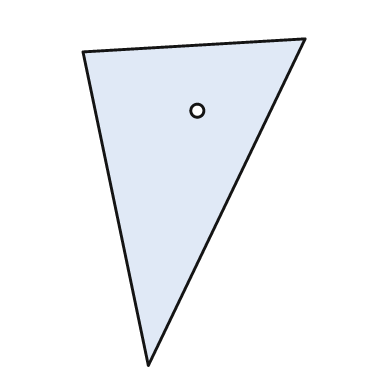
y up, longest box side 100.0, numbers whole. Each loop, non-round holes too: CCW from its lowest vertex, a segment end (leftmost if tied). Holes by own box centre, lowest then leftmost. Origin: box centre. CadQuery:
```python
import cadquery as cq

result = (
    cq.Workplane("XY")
    .moveTo(-14.0, -50.0)
    .lineTo(34.0, 50.0)
    .lineTo(-34.0, 46.0)
    .close()
    .moveTo(1.0, 28.0)
    .circle(2.0)
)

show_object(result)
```